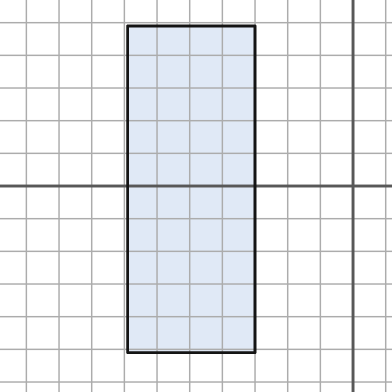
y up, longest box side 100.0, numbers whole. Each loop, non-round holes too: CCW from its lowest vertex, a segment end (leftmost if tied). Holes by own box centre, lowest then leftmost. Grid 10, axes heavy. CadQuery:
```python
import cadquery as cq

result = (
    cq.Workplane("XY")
    .moveTo(-69.0, -51.0)
    .lineTo(-30.0, -51.0)
    .lineTo(-30.0, 49.0)
    .lineTo(-69.0, 49.0)
    .close()
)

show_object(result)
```